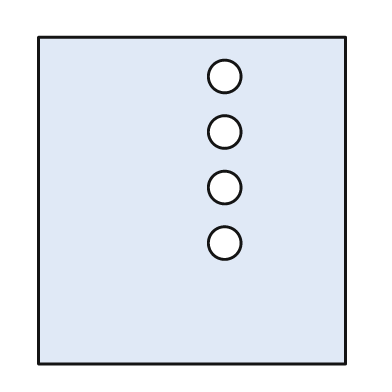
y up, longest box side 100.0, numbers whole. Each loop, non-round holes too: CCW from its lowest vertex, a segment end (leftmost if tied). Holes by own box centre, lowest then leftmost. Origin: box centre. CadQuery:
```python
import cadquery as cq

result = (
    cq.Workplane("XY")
    .moveTo(-47.0, -50.0)
    .lineTo(47.0, -50.0)
    .lineTo(47.0, 50.0)
    .lineTo(-47.0, 50.0)
    .close()
    .moveTo(10.0, -13.0)
    .circle(5.0)
    .moveTo(10.0, 4.0)
    .circle(5.0)
    .moveTo(10.0, 21.0)
    .circle(5.0)
    .moveTo(10.0, 38.0)
    .circle(5.0)
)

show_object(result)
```